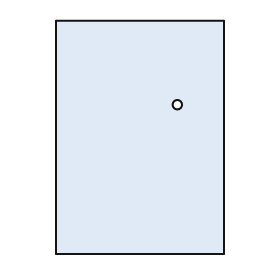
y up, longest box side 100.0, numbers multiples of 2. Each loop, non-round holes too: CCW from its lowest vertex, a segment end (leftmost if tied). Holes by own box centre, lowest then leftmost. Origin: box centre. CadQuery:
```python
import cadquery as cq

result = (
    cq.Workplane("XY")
    .moveTo(-36.0, -50.0)
    .lineTo(36.0, -50.0)
    .lineTo(36.0, 50.0)
    .lineTo(-36.0, 50.0)
    .close()
    .moveTo(16.0, 14.0)
    .circle(2.0)
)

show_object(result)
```